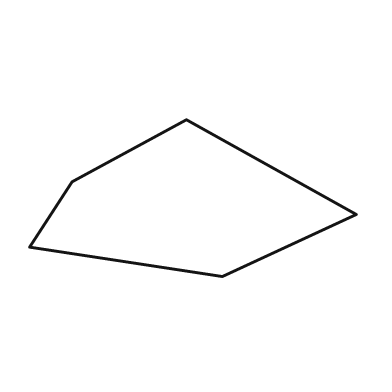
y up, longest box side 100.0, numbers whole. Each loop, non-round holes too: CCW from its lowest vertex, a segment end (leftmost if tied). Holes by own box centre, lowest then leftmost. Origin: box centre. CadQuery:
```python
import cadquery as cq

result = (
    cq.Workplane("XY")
    .moveTo(9.0, -24.0)
    .lineTo(50.0, -5.0)
    .lineTo(-2.0, 24.0)
    .lineTo(-37.0, 5.0)
    .lineTo(-50.0, -15.0)
    .close()
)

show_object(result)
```